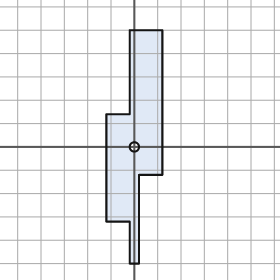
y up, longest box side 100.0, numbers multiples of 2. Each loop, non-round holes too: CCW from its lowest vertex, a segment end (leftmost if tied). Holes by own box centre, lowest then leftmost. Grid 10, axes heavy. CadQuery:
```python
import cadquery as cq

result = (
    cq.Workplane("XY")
    .moveTo(-2.0, -50.0)
    .lineTo(2.0, -50.0)
    .lineTo(2.0, -12.0)
    .lineTo(12.0, -12.0)
    .lineTo(12.0, 50.0)
    .lineTo(-2.0, 50.0)
    .lineTo(-2.0, 14.0)
    .lineTo(-12.0, 14.0)
    .lineTo(-12.0, -32.0)
    .lineTo(-2.0, -32.0)
    .close()
    .moveTo(0.0, 0.0)
    .circle(2.0)
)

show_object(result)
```